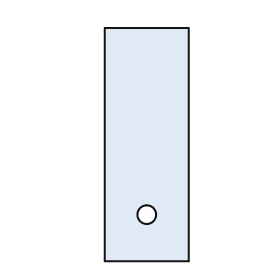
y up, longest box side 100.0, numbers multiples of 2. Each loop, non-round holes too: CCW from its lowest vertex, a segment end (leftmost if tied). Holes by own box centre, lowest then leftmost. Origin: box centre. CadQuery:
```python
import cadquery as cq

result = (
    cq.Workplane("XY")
    .moveTo(-18.0, -50.0)
    .lineTo(18.0, -50.0)
    .lineTo(18.0, 50.0)
    .lineTo(-18.0, 50.0)
    .close()
    .moveTo(0.0, -30.0)
    .circle(4.0)
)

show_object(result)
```